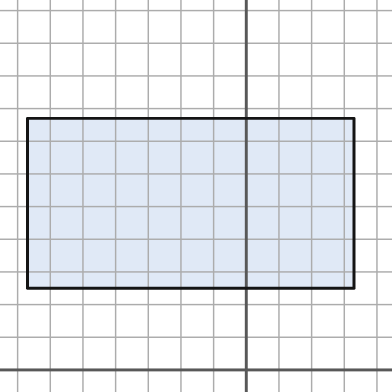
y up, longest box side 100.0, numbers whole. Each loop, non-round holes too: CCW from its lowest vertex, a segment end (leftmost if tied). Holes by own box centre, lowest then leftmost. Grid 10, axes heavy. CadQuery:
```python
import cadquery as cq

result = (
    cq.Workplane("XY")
    .moveTo(-67.0, 25.0)
    .lineTo(33.0, 25.0)
    .lineTo(33.0, 77.0)
    .lineTo(-67.0, 77.0)
    .close()
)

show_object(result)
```